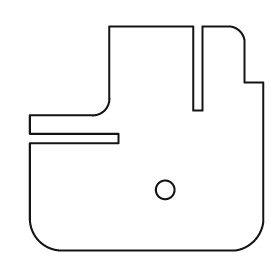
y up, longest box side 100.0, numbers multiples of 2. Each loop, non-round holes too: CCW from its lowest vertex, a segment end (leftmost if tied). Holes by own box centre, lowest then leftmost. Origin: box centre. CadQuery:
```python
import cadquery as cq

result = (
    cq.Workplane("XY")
    .moveTo(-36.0, -48.0)
    .lineTo(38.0, -48.0)
    .threePointArc((46.0, -44.0), (50.0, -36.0))
    .lineTo(50.0, 24.0)
    .lineTo(42.0, 24.0)
    .lineTo(42.0, 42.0)
    .threePointArc((40.0, 46.0), (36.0, 48.0))
    .lineTo(24.0, 48.0)
    .lineTo(24.0, 12.0)
    .lineTo(20.0, 12.0)
    .lineTo(20.0, 48.0)
    .lineTo(-16.0, 48.0)
    .lineTo(-16.0, 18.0)
    .threePointArc((-18.0, 12.0), (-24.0, 10.0))
    .lineTo(-50.0, 10.0)
    .lineTo(-50.0, 2.0)
    .lineTo(-12.0, 2.0)
    .lineTo(-12.0, -2.0)
    .lineTo(-50.0, -2.0)
    .lineTo(-50.0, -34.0)
    .threePointArc((-46.0, -44.0), (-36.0, -48.0))
    .close()
    .moveTo(8.0, -22.0)
    .circle(4.0)
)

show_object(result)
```